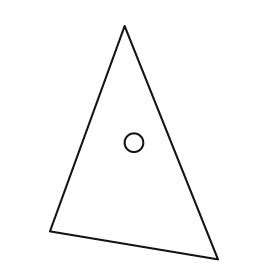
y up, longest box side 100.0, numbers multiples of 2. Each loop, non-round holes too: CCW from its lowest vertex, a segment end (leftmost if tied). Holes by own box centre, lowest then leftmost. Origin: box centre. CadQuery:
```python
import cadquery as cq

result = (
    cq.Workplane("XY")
    .moveTo(36.0, -50.0)
    .lineTo(-4.0, 50.0)
    .lineTo(-36.0, -38.0)
    .close()
    .moveTo(0.0, 0.0)
    .circle(4.0)
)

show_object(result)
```